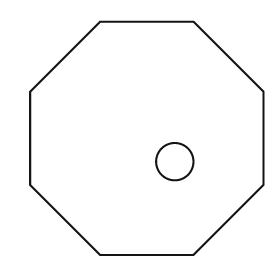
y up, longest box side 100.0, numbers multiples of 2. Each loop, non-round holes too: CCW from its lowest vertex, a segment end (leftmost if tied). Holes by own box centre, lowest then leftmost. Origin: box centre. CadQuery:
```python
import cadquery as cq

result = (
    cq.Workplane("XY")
    .moveTo(-20.0, -50.0)
    .lineTo(20.0, -50.0)
    .lineTo(50.0, -20.0)
    .lineTo(50.0, 20.0)
    .lineTo(20.0, 50.0)
    .lineTo(-20.0, 50.0)
    .lineTo(-50.0, 20.0)
    .lineTo(-50.0, -20.0)
    .close()
    .moveTo(12.0, -10.0)
    .circle(8.0)
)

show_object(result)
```